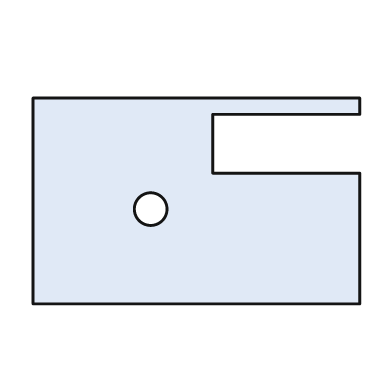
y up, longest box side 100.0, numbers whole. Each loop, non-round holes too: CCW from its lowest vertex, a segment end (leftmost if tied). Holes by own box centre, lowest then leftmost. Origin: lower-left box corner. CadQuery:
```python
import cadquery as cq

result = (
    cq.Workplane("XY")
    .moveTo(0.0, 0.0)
    .lineTo(100.0, 0.0)
    .lineTo(100.0, 40.0)
    .lineTo(55.0, 40.0)
    .lineTo(55.0, 58.0)
    .lineTo(100.0, 58.0)
    .lineTo(100.0, 63.0)
    .lineTo(0.0, 63.0)
    .close()
    .moveTo(36.0, 29.0)
    .circle(5.0)
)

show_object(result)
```